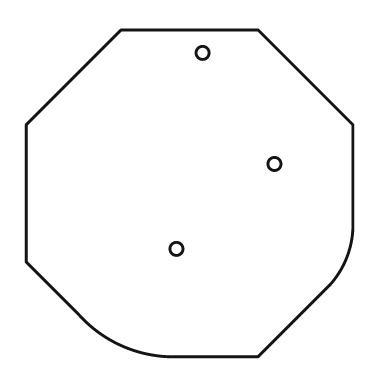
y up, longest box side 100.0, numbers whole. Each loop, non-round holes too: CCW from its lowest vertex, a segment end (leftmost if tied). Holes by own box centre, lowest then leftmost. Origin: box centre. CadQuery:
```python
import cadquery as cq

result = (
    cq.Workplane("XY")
    .moveTo(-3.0, -50.0)
    .lineTo(21.0, -50.0)
    .lineTo(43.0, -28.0)
    .threePointArc((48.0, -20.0), (50.0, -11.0))
    .lineTo(50.0, 21.0)
    .lineTo(21.0, 50.0)
    .lineTo(-21.0, 50.0)
    .lineTo(-50.0, 21.0)
    .lineTo(-50.0, -21.0)
    .lineTo(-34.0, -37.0)
    .threePointArc((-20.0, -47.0), (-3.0, -50.0))
    .close()
    .moveTo(-4.0, -17.0)
    .circle(2.0)
    .moveTo(26.0, 9.0)
    .circle(2.0)
    .moveTo(4.0, 43.0)
    .circle(2.0)
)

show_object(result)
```